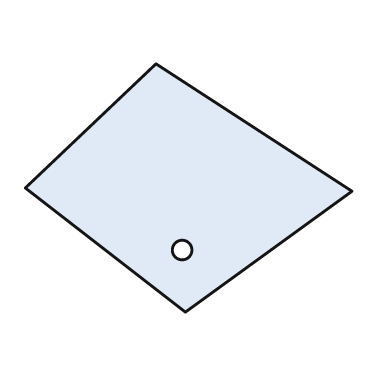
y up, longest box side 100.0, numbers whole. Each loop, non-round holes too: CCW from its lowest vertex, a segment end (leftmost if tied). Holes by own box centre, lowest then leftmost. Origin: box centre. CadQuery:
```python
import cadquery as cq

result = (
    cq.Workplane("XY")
    .moveTo(-1.0, -38.0)
    .lineTo(50.0, -1.0)
    .lineTo(-10.0, 38.0)
    .lineTo(-50.0, 0.0)
    .close()
    .moveTo(-2.0, -19.0)
    .circle(3.0)
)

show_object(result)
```